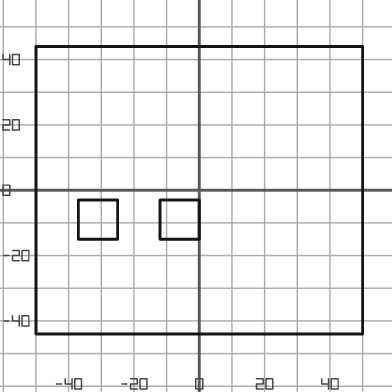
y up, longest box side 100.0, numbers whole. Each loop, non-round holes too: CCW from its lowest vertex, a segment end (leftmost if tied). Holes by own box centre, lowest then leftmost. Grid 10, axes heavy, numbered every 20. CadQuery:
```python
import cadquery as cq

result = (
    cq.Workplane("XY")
    .moveTo(-50.0, -44.0)
    .lineTo(50.0, -44.0)
    .lineTo(50.0, 44.0)
    .lineTo(-50.0, 44.0)
    .close()
    .moveTo(-37.0, -15.0)
    .lineTo(-25.0, -15.0)
    .lineTo(-25.0, -3.0)
    .lineTo(-37.0, -3.0)
    .close()
    .moveTo(-12.0, -15.0)
    .lineTo(0.0, -15.0)
    .lineTo(0.0, -3.0)
    .lineTo(-12.0, -3.0)
    .close()
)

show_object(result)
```